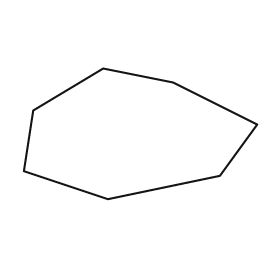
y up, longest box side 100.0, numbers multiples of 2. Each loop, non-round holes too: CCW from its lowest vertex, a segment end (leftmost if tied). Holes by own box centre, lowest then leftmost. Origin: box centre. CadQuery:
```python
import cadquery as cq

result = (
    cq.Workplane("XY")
    .moveTo(-14.0, -28.0)
    .lineTo(34.0, -18.0)
    .lineTo(50.0, 4.0)
    .lineTo(14.0, 22.0)
    .lineTo(-16.0, 28.0)
    .lineTo(-46.0, 10.0)
    .lineTo(-50.0, -16.0)
    .close()
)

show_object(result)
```